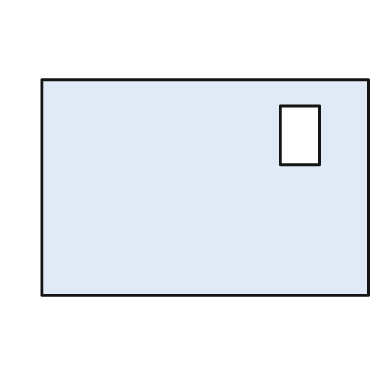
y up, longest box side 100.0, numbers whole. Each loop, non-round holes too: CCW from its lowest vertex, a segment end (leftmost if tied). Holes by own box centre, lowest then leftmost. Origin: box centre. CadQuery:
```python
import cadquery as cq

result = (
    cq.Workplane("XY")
    .moveTo(-50.0, -33.0)
    .lineTo(50.0, -33.0)
    .lineTo(50.0, 33.0)
    .lineTo(-50.0, 33.0)
    .close()
    .moveTo(23.0, 7.0)
    .lineTo(35.0, 7.0)
    .lineTo(35.0, 25.0)
    .lineTo(23.0, 25.0)
    .close()
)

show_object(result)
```